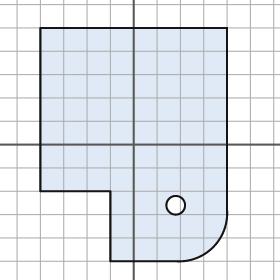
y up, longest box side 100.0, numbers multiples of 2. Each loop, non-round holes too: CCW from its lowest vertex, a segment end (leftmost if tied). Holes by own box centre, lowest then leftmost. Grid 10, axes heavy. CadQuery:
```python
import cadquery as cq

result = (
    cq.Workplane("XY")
    .moveTo(-10.0, -50.0)
    .lineTo(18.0, -50.0)
    .threePointArc((34.0, -44.0), (40.0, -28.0))
    .lineTo(40.0, 50.0)
    .lineTo(-40.0, 50.0)
    .lineTo(-40.0, -20.0)
    .lineTo(-10.0, -20.0)
    .close()
    .moveTo(18.0, -26.0)
    .circle(4.0)
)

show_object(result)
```